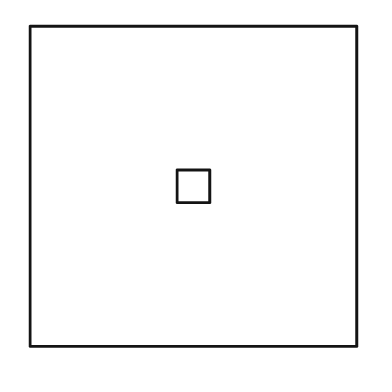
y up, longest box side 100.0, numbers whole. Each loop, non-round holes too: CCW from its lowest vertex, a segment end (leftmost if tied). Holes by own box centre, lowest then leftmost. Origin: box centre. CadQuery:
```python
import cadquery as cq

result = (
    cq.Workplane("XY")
    .moveTo(-50.0, -49.0)
    .lineTo(50.0, -49.0)
    .lineTo(50.0, 49.0)
    .lineTo(-50.0, 49.0)
    .close()
    .moveTo(-5.0, -5.0)
    .lineTo(5.0, -5.0)
    .lineTo(5.0, 5.0)
    .lineTo(-5.0, 5.0)
    .close()
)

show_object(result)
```